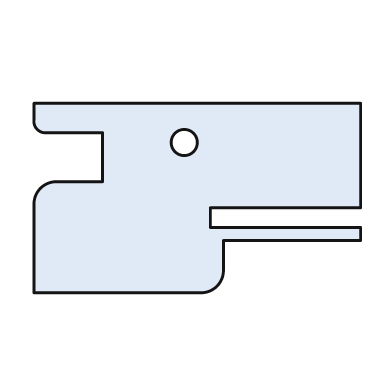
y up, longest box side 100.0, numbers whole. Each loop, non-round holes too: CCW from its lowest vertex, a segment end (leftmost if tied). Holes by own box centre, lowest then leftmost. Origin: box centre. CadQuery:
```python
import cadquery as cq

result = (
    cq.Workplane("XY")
    .moveTo(-50.0, -29.0)
    .lineTo(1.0, -29.0)
    .threePointArc((6.0, -27.0), (8.0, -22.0))
    .lineTo(8.0, -13.0)
    .lineTo(50.0, -13.0)
    .lineTo(50.0, -9.0)
    .lineTo(4.0, -9.0)
    .lineTo(4.0, -3.0)
    .lineTo(50.0, -3.0)
    .lineTo(50.0, 29.0)
    .lineTo(-50.0, 29.0)
    .lineTo(-50.0, 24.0)
    .threePointArc((-49.0, 21.0), (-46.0, 20.0))
    .lineTo(-29.0, 20.0)
    .lineTo(-29.0, 5.0)
    .lineTo(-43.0, 5.0)
    .threePointArc((-48.0, 3.0), (-50.0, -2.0))
    .close()
    .moveTo(-4.0, 17.0)
    .circle(4.0)
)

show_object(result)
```